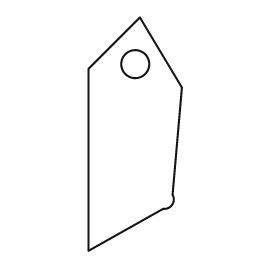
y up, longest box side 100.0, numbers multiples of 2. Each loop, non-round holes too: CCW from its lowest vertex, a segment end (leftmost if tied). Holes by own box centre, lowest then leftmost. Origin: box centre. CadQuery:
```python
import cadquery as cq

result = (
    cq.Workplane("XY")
    .moveTo(-20.0, -50.0)
    .lineTo(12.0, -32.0)
    .threePointArc((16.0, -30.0), (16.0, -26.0))
    .lineTo(20.0, 20.0)
    .lineTo(2.0, 50.0)
    .lineTo(-20.0, 28.0)
    .close()
    .moveTo(0.0, 30.0)
    .circle(6.0)
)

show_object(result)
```